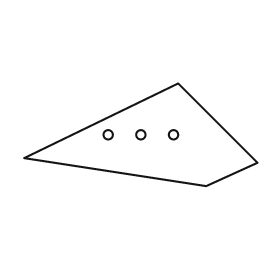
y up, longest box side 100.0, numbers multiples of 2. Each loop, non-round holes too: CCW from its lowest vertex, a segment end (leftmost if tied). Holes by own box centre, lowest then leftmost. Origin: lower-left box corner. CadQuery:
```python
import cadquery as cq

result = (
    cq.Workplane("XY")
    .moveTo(78.0, 0.0)
    .lineTo(100.0, 10.0)
    .lineTo(66.0, 44.0)
    .lineTo(0.0, 12.0)
    .close()
    .moveTo(36.0, 22.0)
    .circle(2.0)
    .moveTo(50.0, 22.0)
    .circle(2.0)
    .moveTo(64.0, 22.0)
    .circle(2.0)
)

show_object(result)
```